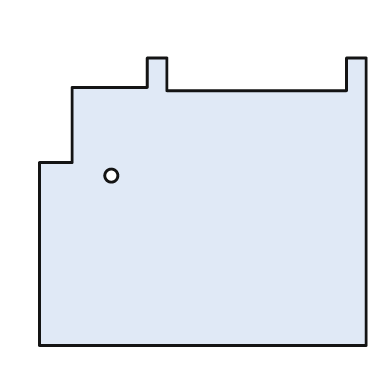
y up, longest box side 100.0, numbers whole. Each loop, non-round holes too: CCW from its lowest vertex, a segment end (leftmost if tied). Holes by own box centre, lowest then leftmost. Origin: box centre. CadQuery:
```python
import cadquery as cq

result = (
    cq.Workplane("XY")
    .moveTo(-50.0, -44.0)
    .lineTo(50.0, -44.0)
    .lineTo(50.0, 44.0)
    .lineTo(44.0, 44.0)
    .lineTo(44.0, 34.0)
    .lineTo(-11.0, 34.0)
    .lineTo(-11.0, 44.0)
    .lineTo(-17.0, 44.0)
    .lineTo(-17.0, 35.0)
    .lineTo(-40.0, 35.0)
    .lineTo(-40.0, 12.0)
    .lineTo(-50.0, 12.0)
    .close()
    .moveTo(-28.0, 8.0)
    .circle(2.0)
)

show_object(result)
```